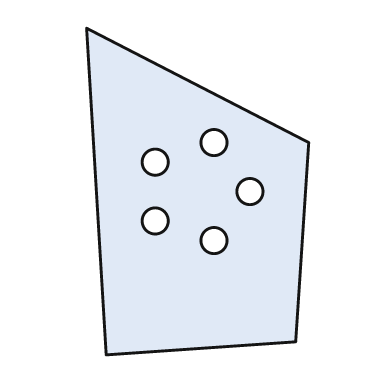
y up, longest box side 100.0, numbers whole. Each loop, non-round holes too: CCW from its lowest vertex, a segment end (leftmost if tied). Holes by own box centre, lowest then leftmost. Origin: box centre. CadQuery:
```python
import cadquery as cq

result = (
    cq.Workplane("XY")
    .moveTo(-28.0, -50.0)
    .lineTo(30.0, -46.0)
    .lineTo(34.0, 15.0)
    .lineTo(-34.0, 50.0)
    .close()
    .moveTo(5.0, -15.0)
    .circle(4.0)
    .moveTo(-13.0, -9.0)
    .circle(4.0)
    .moveTo(16.0, 0.0)
    .circle(4.0)
    .moveTo(-13.0, 9.0)
    .circle(4.0)
    .moveTo(5.0, 15.0)
    .circle(4.0)
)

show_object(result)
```